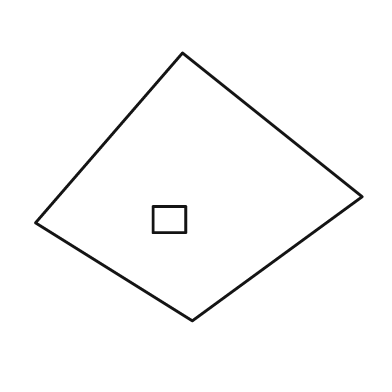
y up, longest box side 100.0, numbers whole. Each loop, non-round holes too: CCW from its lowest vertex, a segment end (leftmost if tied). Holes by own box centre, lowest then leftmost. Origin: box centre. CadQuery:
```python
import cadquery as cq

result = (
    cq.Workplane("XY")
    .moveTo(-2.0, -41.0)
    .lineTo(50.0, -3.0)
    .lineTo(-5.0, 41.0)
    .lineTo(-50.0, -11.0)
    .close()
    .moveTo(-14.0, -14.0)
    .lineTo(-4.0, -14.0)
    .lineTo(-4.0, -6.0)
    .lineTo(-14.0, -6.0)
    .close()
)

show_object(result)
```